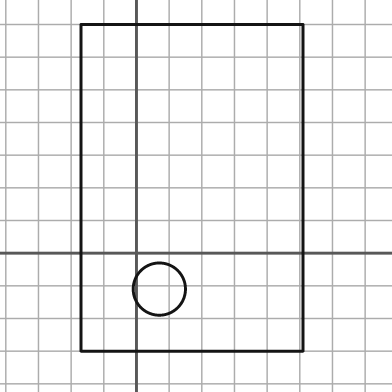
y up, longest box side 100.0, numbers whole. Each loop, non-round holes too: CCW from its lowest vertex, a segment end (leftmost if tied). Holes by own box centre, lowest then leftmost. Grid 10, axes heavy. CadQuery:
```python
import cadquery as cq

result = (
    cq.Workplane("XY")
    .moveTo(-17.0, -30.0)
    .lineTo(51.0, -30.0)
    .lineTo(51.0, 70.0)
    .lineTo(-17.0, 70.0)
    .close()
    .moveTo(7.0, -11.0)
    .circle(8.0)
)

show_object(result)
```